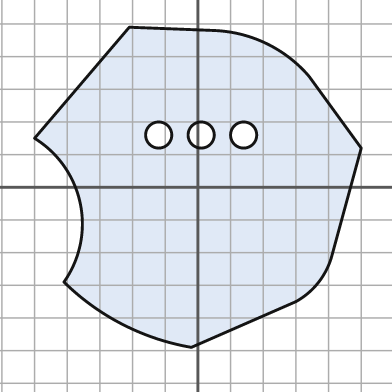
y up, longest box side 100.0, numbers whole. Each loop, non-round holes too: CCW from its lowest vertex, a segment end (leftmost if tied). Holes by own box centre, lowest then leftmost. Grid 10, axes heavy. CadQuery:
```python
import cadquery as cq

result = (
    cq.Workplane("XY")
    .moveTo(-2.0, -49.0)
    .lineTo(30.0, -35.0)
    .threePointArc((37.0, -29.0), (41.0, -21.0))
    .lineTo(50.0, 12.0)
    .lineTo(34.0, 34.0)
    .threePointArc((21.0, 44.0), (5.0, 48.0))
    .lineTo(-21.0, 49.0)
    .lineTo(-50.0, 15.0)
    .threePointArc((-36.0, -5.0), (-41.0, -29.0))
    .threePointArc((-23.0, -42.0), (-2.0, -49.0))
    .close()
    .moveTo(-12.0, 16.0)
    .circle(4.0)
    .moveTo(1.0, 16.0)
    .circle(4.0)
    .moveTo(14.0, 16.0)
    .circle(4.0)
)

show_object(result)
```